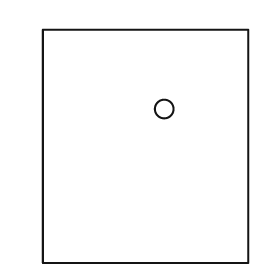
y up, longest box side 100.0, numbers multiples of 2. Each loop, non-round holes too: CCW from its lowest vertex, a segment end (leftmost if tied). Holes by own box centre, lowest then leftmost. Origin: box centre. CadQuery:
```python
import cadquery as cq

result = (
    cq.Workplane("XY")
    .moveTo(-44.0, -50.0)
    .lineTo(44.0, -50.0)
    .lineTo(44.0, 50.0)
    .lineTo(-44.0, 50.0)
    .close()
    .moveTo(8.0, 16.0)
    .circle(4.0)
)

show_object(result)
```